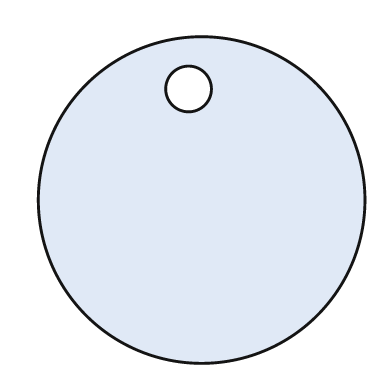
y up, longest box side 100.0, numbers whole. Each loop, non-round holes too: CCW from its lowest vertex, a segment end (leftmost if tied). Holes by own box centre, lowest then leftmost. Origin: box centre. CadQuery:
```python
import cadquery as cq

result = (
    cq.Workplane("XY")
    .moveTo(0.0, 0.0)
    .circle(50.0)
    .moveTo(-4.0, 34.0)
    .circle(7.0)
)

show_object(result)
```